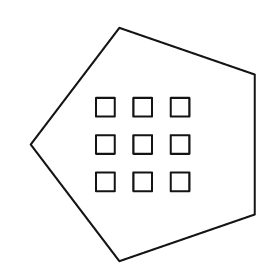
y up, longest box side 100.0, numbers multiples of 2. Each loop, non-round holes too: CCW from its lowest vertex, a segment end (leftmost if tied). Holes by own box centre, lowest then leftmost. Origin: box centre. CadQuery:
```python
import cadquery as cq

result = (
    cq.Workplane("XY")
    .moveTo(-10.0, -50.0)
    .lineTo(48.0, -30.0)
    .lineTo(48.0, 30.0)
    .lineTo(-10.0, 50.0)
    .lineTo(-48.0, 0.0)
    .close()
    .moveTo(-20.0, -20.0)
    .lineTo(-12.0, -20.0)
    .lineTo(-12.0, -12.0)
    .lineTo(-20.0, -12.0)
    .close()
    .moveTo(-4.0, -20.0)
    .lineTo(4.0, -20.0)
    .lineTo(4.0, -12.0)
    .lineTo(-4.0, -12.0)
    .close()
    .moveTo(12.0, -20.0)
    .lineTo(20.0, -20.0)
    .lineTo(20.0, -12.0)
    .lineTo(12.0, -12.0)
    .close()
    .moveTo(-20.0, -4.0)
    .lineTo(-12.0, -4.0)
    .lineTo(-12.0, 4.0)
    .lineTo(-20.0, 4.0)
    .close()
    .moveTo(-4.0, -4.0)
    .lineTo(4.0, -4.0)
    .lineTo(4.0, 4.0)
    .lineTo(-4.0, 4.0)
    .close()
    .moveTo(12.0, -4.0)
    .lineTo(20.0, -4.0)
    .lineTo(20.0, 4.0)
    .lineTo(12.0, 4.0)
    .close()
    .moveTo(-20.0, 12.0)
    .lineTo(-12.0, 12.0)
    .lineTo(-12.0, 20.0)
    .lineTo(-20.0, 20.0)
    .close()
    .moveTo(-4.0, 12.0)
    .lineTo(4.0, 12.0)
    .lineTo(4.0, 20.0)
    .lineTo(-4.0, 20.0)
    .close()
    .moveTo(12.0, 12.0)
    .lineTo(20.0, 12.0)
    .lineTo(20.0, 20.0)
    .lineTo(12.0, 20.0)
    .close()
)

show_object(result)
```